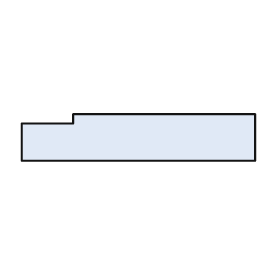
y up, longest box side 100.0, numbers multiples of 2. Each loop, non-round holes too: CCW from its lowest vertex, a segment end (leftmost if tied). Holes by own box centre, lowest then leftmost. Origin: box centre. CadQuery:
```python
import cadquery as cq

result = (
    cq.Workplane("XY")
    .moveTo(-50.0, -10.0)
    .lineTo(50.0, -10.0)
    .lineTo(50.0, 10.0)
    .lineTo(-28.0, 10.0)
    .lineTo(-28.0, 6.0)
    .lineTo(-50.0, 6.0)
    .close()
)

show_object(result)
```